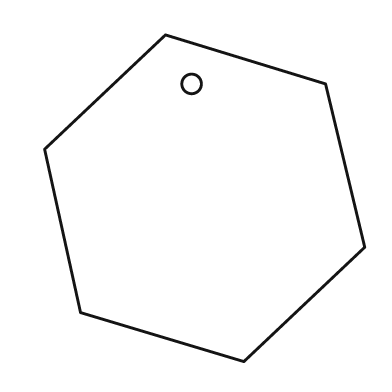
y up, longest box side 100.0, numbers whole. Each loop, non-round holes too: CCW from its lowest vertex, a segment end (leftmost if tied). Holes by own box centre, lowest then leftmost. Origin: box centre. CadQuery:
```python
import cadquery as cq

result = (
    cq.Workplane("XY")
    .moveTo(12.0, -50.0)
    .lineTo(49.0, -15.0)
    .lineTo(37.0, 35.0)
    .lineTo(-12.0, 50.0)
    .lineTo(-49.0, 15.0)
    .lineTo(-38.0, -35.0)
    .close()
    .moveTo(-4.0, 35.0)
    .circle(3.0)
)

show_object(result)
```